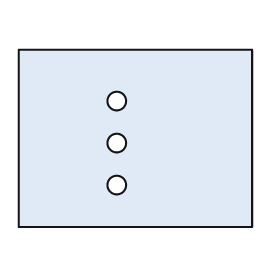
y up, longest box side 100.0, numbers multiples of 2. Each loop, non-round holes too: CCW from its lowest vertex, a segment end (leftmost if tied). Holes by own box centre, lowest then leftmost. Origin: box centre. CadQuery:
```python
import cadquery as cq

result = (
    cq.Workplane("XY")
    .moveTo(-50.0, -38.0)
    .lineTo(50.0, -38.0)
    .lineTo(50.0, 38.0)
    .lineTo(-50.0, 38.0)
    .close()
    .moveTo(-8.0, -20.0)
    .circle(4.0)
    .moveTo(-8.0, -2.0)
    .circle(4.0)
    .moveTo(-8.0, 16.0)
    .circle(4.0)
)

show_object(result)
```